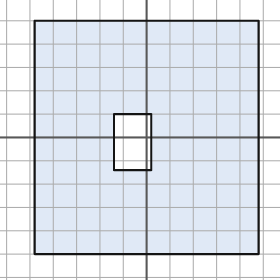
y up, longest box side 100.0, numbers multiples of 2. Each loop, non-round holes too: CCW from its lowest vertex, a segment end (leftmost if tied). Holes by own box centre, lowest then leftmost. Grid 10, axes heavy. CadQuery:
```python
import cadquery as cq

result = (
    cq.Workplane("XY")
    .moveTo(-48.0, -50.0)
    .lineTo(48.0, -50.0)
    .lineTo(48.0, 50.0)
    .lineTo(-48.0, 50.0)
    .close()
    .moveTo(-14.0, -14.0)
    .lineTo(2.0, -14.0)
    .lineTo(2.0, 10.0)
    .lineTo(-14.0, 10.0)
    .close()
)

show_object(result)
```